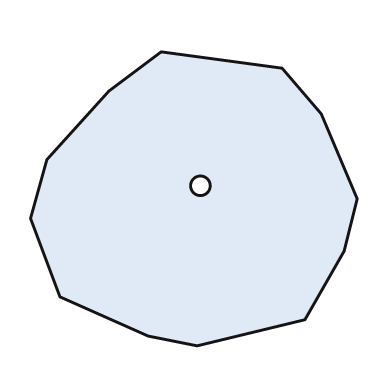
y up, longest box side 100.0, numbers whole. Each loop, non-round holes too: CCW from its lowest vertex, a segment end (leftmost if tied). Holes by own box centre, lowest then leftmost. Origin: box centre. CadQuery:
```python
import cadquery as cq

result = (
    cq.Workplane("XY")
    .moveTo(1.0, -45.0)
    .lineTo(34.0, -37.0)
    .lineTo(46.0, -16.0)
    .lineTo(50.0, 0.0)
    .lineTo(39.0, 26.0)
    .lineTo(27.0, 40.0)
    .lineTo(-10.0, 45.0)
    .lineTo(-26.0, 33.0)
    .lineTo(-45.0, 12.0)
    .lineTo(-50.0, -6.0)
    .lineTo(-41.0, -30.0)
    .lineTo(-14.0, -42.0)
    .close()
    .moveTo(2.0, 4.0)
    .circle(3.0)
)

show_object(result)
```